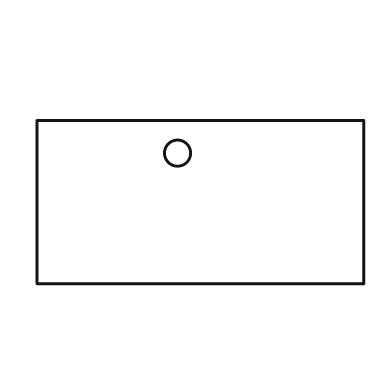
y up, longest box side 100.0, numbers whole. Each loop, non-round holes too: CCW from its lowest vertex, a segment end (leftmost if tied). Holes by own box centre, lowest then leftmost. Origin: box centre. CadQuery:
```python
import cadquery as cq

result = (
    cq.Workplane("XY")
    .moveTo(-50.0, -25.0)
    .lineTo(50.0, -25.0)
    .lineTo(50.0, 25.0)
    .lineTo(-50.0, 25.0)
    .close()
    .moveTo(-7.0, 15.0)
    .circle(4.0)
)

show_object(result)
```